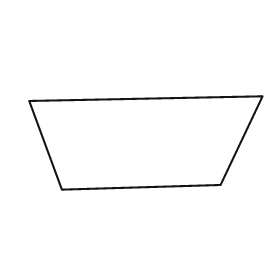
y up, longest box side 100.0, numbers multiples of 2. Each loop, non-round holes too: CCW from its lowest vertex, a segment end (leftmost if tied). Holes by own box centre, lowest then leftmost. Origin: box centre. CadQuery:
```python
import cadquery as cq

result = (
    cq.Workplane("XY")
    .moveTo(-36.0, -20.0)
    .lineTo(32.0, -18.0)
    .lineTo(50.0, 20.0)
    .lineTo(-50.0, 18.0)
    .close()
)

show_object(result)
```